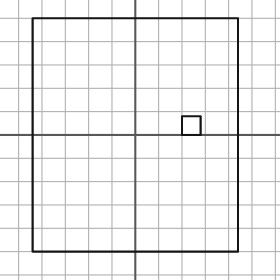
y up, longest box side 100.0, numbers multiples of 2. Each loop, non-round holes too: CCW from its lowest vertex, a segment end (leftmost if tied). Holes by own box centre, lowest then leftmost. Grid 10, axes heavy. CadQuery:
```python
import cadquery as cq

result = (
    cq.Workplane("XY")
    .moveTo(-44.0, -50.0)
    .lineTo(44.0, -50.0)
    .lineTo(44.0, 50.0)
    .lineTo(-44.0, 50.0)
    .close()
    .moveTo(20.0, 0.0)
    .lineTo(28.0, 0.0)
    .lineTo(28.0, 8.0)
    .lineTo(20.0, 8.0)
    .close()
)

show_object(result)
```